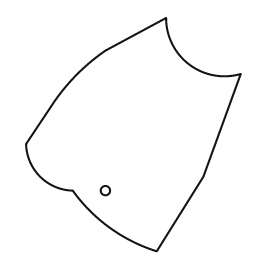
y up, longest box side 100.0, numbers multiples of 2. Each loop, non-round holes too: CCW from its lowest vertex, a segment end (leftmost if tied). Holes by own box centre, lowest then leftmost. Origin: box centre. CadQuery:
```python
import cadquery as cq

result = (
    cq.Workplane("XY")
    .moveTo(10.0, -50.0)
    .lineTo(30.0, -18.0)
    .lineTo(46.0, 26.0)
    .threePointArc((24.0, 30.0), (14.0, 50.0))
    .lineTo(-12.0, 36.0)
    .threePointArc((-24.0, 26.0), (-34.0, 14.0))
    .lineTo(-46.0, -4.0)
    .threePointArc((-40.0, -18.0), (-26.0, -24.0))
    .threePointArc((-10.0, -40.0), (10.0, -50.0))
    .close()
    .moveTo(-12.0, -24.0)
    .circle(2.0)
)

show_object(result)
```